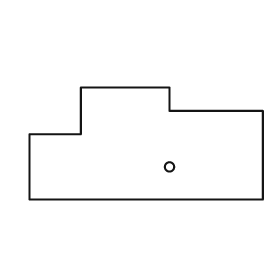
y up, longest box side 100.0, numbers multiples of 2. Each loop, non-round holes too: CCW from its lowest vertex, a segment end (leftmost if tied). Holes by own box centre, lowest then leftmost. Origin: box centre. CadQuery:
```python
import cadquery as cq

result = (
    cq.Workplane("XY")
    .moveTo(-50.0, -24.0)
    .lineTo(50.0, -24.0)
    .lineTo(50.0, 14.0)
    .lineTo(10.0, 14.0)
    .lineTo(10.0, 24.0)
    .lineTo(-28.0, 24.0)
    .lineTo(-28.0, 4.0)
    .lineTo(-50.0, 4.0)
    .close()
    .moveTo(10.0, -10.0)
    .circle(2.0)
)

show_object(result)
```